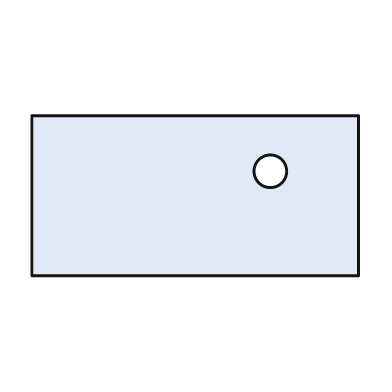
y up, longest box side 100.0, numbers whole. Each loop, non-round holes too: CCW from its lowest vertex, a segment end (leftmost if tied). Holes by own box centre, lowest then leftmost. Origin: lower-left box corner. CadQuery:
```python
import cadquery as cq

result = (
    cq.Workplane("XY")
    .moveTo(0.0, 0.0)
    .lineTo(100.0, 0.0)
    .lineTo(100.0, 49.0)
    .lineTo(0.0, 49.0)
    .close()
    .moveTo(73.0, 32.0)
    .circle(5.0)
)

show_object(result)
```